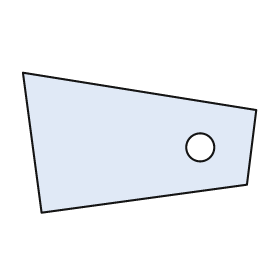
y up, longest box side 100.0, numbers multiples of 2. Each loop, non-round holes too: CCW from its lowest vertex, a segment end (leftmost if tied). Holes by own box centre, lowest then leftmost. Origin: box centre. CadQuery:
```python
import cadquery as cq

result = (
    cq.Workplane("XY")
    .moveTo(-42.0, -30.0)
    .lineTo(46.0, -18.0)
    .lineTo(50.0, 14.0)
    .lineTo(-50.0, 30.0)
    .close()
    .moveTo(26.0, -2.0)
    .circle(6.0)
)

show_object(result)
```